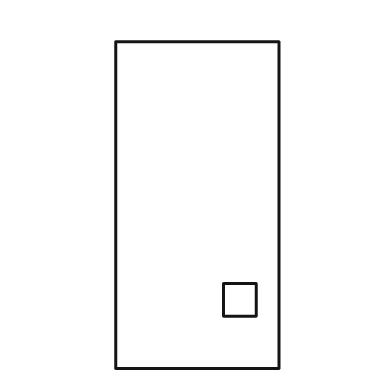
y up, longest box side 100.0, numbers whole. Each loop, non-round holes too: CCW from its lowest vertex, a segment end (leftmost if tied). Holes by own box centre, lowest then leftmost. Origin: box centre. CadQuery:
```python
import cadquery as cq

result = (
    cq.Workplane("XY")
    .moveTo(-25.0, -50.0)
    .lineTo(25.0, -50.0)
    .lineTo(25.0, 50.0)
    .lineTo(-25.0, 50.0)
    .close()
    .moveTo(8.0, -34.0)
    .lineTo(18.0, -34.0)
    .lineTo(18.0, -24.0)
    .lineTo(8.0, -24.0)
    .close()
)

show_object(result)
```